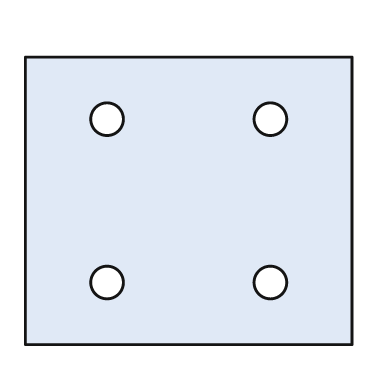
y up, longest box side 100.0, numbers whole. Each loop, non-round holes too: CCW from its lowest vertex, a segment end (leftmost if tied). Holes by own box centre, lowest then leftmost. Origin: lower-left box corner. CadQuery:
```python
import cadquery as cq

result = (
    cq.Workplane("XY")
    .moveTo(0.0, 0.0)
    .lineTo(100.0, 0.0)
    .lineTo(100.0, 88.0)
    .lineTo(0.0, 88.0)
    .close()
    .moveTo(25.0, 19.0)
    .circle(5.0)
    .moveTo(75.0, 19.0)
    .circle(5.0)
    .moveTo(25.0, 69.0)
    .circle(5.0)
    .moveTo(75.0, 69.0)
    .circle(5.0)
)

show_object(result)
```